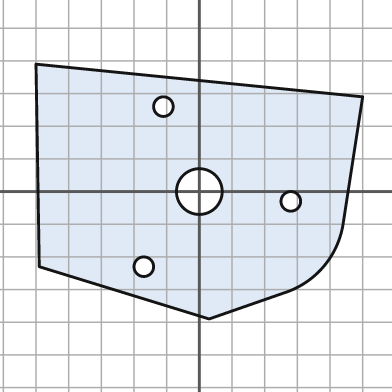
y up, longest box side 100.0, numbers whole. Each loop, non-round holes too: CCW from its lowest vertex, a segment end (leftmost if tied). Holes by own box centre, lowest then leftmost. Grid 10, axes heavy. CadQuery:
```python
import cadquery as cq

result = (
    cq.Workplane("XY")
    .moveTo(3.0, -39.0)
    .lineTo(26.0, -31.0)
    .threePointArc((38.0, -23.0), (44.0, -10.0))
    .lineTo(50.0, 29.0)
    .lineTo(-50.0, 39.0)
    .lineTo(-49.0, -23.0)
    .close()
    .moveTo(-17.0, -23.0)
    .circle(3.0)
    .moveTo(28.0, -3.0)
    .circle(3.0)
    .moveTo(0.0, 0.0)
    .circle(7.0)
    .moveTo(-11.0, 26.0)
    .circle(3.0)
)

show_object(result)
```